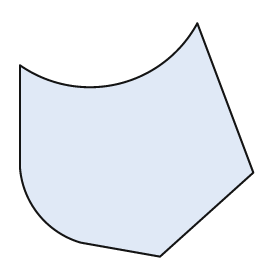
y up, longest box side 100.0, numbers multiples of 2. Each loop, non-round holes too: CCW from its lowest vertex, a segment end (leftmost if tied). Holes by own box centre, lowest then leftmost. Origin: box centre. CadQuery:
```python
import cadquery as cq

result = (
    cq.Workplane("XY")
    .moveTo(10.0, -50.0)
    .lineTo(50.0, -14.0)
    .lineTo(26.0, 50.0)
    .threePointArc((-8.0, 24.0), (-50.0, 32.0))
    .lineTo(-50.0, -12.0)
    .threePointArc((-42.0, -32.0), (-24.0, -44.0))
    .close()
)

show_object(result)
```